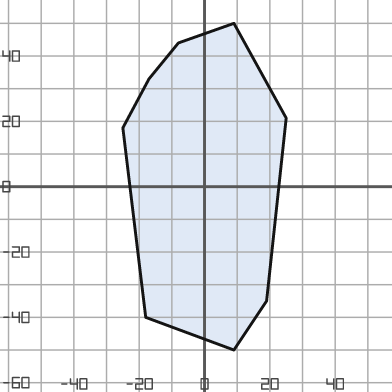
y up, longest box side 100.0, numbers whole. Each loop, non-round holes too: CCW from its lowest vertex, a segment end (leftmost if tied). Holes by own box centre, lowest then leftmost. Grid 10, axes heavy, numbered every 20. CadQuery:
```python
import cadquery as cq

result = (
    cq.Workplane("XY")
    .moveTo(9.0, -50.0)
    .lineTo(19.0, -35.0)
    .lineTo(25.0, 21.0)
    .lineTo(9.0, 50.0)
    .lineTo(-8.0, 44.0)
    .lineTo(-17.0, 33.0)
    .lineTo(-25.0, 18.0)
    .lineTo(-18.0, -40.0)
    .close()
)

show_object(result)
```